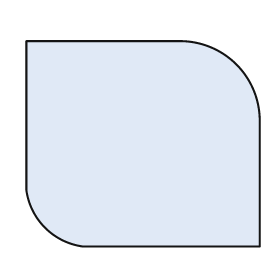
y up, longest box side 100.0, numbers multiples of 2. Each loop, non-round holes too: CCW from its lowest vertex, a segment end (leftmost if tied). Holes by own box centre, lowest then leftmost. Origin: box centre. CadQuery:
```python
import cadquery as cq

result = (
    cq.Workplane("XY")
    .moveTo(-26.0, -44.0)
    .lineTo(50.0, -44.0)
    .lineTo(50.0, 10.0)
    .threePointArc((40.0, 34.0), (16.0, 44.0))
    .lineTo(-50.0, 44.0)
    .lineTo(-50.0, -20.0)
    .threePointArc((-42.0, -36.0), (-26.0, -44.0))
    .close()
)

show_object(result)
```